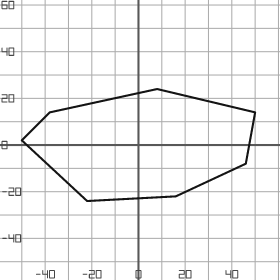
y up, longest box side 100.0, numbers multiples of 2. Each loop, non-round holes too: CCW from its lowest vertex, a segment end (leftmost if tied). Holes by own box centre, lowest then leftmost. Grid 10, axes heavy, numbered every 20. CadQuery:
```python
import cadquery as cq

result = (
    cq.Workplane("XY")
    .moveTo(-22.0, -24.0)
    .lineTo(16.0, -22.0)
    .lineTo(46.0, -8.0)
    .lineTo(50.0, 14.0)
    .lineTo(8.0, 24.0)
    .lineTo(-38.0, 14.0)
    .lineTo(-50.0, 2.0)
    .close()
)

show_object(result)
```